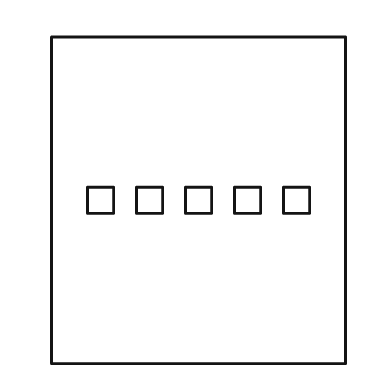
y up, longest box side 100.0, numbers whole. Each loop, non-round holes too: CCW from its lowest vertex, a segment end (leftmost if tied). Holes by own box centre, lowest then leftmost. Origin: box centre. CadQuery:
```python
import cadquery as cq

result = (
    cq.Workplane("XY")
    .moveTo(-45.0, -50.0)
    .lineTo(45.0, -50.0)
    .lineTo(45.0, 50.0)
    .lineTo(-45.0, 50.0)
    .close()
    .moveTo(-34.0, -4.0)
    .lineTo(-26.0, -4.0)
    .lineTo(-26.0, 4.0)
    .lineTo(-34.0, 4.0)
    .close()
    .moveTo(-19.0, -4.0)
    .lineTo(-11.0, -4.0)
    .lineTo(-11.0, 4.0)
    .lineTo(-19.0, 4.0)
    .close()
    .moveTo(-4.0, -4.0)
    .lineTo(4.0, -4.0)
    .lineTo(4.0, 4.0)
    .lineTo(-4.0, 4.0)
    .close()
    .moveTo(11.0, -4.0)
    .lineTo(19.0, -4.0)
    .lineTo(19.0, 4.0)
    .lineTo(11.0, 4.0)
    .close()
    .moveTo(26.0, -4.0)
    .lineTo(34.0, -4.0)
    .lineTo(34.0, 4.0)
    .lineTo(26.0, 4.0)
    .close()
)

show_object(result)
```